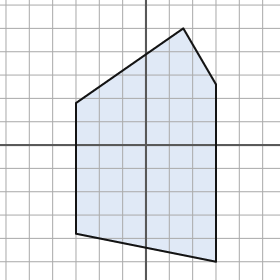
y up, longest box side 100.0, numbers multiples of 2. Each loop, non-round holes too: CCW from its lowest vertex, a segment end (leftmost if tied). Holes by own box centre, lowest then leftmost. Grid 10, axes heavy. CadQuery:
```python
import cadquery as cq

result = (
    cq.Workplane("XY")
    .moveTo(30.0, -50.0)
    .lineTo(30.0, 26.0)
    .lineTo(16.0, 50.0)
    .lineTo(-30.0, 18.0)
    .lineTo(-30.0, -38.0)
    .close()
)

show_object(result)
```